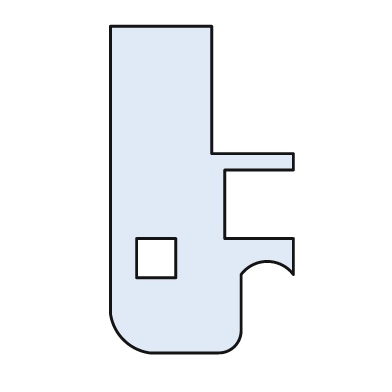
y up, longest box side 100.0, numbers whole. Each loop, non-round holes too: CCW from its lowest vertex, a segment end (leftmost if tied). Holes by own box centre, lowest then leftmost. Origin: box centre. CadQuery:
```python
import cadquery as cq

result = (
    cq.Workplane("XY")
    .moveTo(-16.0, -50.0)
    .lineTo(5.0, -50.0)
    .threePointArc((10.0, -48.0), (12.0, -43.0))
    .lineTo(12.0, -26.0)
    .threePointArc((20.0, -22.0), (28.0, -26.0))
    .lineTo(28.0, -15.0)
    .lineTo(7.0, -15.0)
    .lineTo(7.0, 6.0)
    .lineTo(28.0, 6.0)
    .lineTo(28.0, 11.0)
    .lineTo(3.0, 11.0)
    .lineTo(3.0, 50.0)
    .lineTo(-28.0, 50.0)
    .lineTo(-28.0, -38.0)
    .threePointArc((-24.0, -46.0), (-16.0, -50.0))
    .close()
    .moveTo(-20.0, -27.0)
    .lineTo(-8.0, -27.0)
    .lineTo(-8.0, -15.0)
    .lineTo(-20.0, -15.0)
    .close()
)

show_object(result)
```